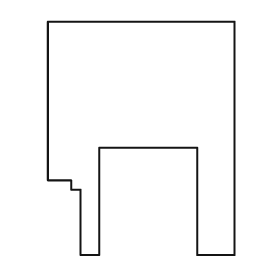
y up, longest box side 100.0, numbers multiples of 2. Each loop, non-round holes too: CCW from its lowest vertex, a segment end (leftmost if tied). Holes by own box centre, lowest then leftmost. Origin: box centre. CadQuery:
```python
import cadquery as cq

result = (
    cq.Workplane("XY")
    .moveTo(-26.0, -50.0)
    .lineTo(-18.0, -50.0)
    .lineTo(-18.0, -4.0)
    .lineTo(24.0, -4.0)
    .lineTo(24.0, -50.0)
    .lineTo(40.0, -50.0)
    .lineTo(40.0, 50.0)
    .lineTo(-40.0, 50.0)
    .lineTo(-40.0, -18.0)
    .lineTo(-30.0, -18.0)
    .lineTo(-30.0, -22.0)
    .lineTo(-26.0, -22.0)
    .close()
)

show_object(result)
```